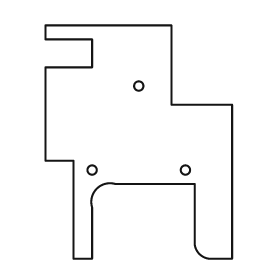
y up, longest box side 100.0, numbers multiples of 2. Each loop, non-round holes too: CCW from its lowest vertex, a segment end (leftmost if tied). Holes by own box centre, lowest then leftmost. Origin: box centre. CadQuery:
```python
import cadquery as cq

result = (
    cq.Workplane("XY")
    .moveTo(-28.0, -50.0)
    .lineTo(-20.0, -50.0)
    .lineTo(-20.0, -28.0)
    .threePointArc((-18.0, -20.0), (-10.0, -18.0))
    .lineTo(24.0, -18.0)
    .lineTo(24.0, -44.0)
    .threePointArc((26.0, -48.0), (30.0, -50.0))
    .lineTo(40.0, -50.0)
    .lineTo(40.0, 16.0)
    .lineTo(14.0, 16.0)
    .lineTo(14.0, 50.0)
    .lineTo(-40.0, 50.0)
    .lineTo(-40.0, 44.0)
    .lineTo(-20.0, 44.0)
    .lineTo(-20.0, 32.0)
    .lineTo(-40.0, 32.0)
    .lineTo(-40.0, -8.0)
    .lineTo(-28.0, -8.0)
    .close()
    .moveTo(-20.0, -12.0)
    .circle(2.0)
    .moveTo(20.0, -12.0)
    .circle(2.0)
    .moveTo(0.0, 24.0)
    .circle(2.0)
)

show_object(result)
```